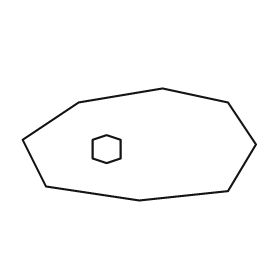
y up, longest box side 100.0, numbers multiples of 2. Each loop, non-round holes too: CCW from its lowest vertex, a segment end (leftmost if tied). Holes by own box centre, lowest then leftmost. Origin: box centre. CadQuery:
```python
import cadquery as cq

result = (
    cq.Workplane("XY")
    .moveTo(0.0, -24.0)
    .lineTo(38.0, -20.0)
    .lineTo(50.0, 0.0)
    .lineTo(38.0, 18.0)
    .lineTo(10.0, 24.0)
    .lineTo(-26.0, 18.0)
    .lineTo(-50.0, 2.0)
    .lineTo(-40.0, -18.0)
    .close()
    .moveTo(-14.0, -8.0)
    .lineTo(-8.0, -6.0)
    .lineTo(-8.0, 2.0)
    .lineTo(-14.0, 4.0)
    .lineTo(-20.0, 2.0)
    .lineTo(-20.0, -6.0)
    .close()
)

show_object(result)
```